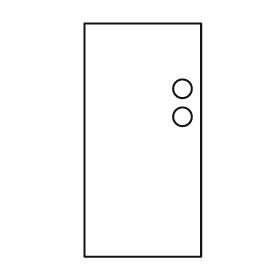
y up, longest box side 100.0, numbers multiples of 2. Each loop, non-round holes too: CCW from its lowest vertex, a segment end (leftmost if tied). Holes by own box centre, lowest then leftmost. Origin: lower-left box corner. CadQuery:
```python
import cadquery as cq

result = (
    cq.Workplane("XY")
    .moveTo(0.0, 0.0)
    .lineTo(50.0, 0.0)
    .lineTo(50.0, 100.0)
    .lineTo(0.0, 100.0)
    .close()
    .moveTo(42.0, 60.0)
    .circle(4.0)
    .moveTo(42.0, 72.0)
    .circle(4.0)
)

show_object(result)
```